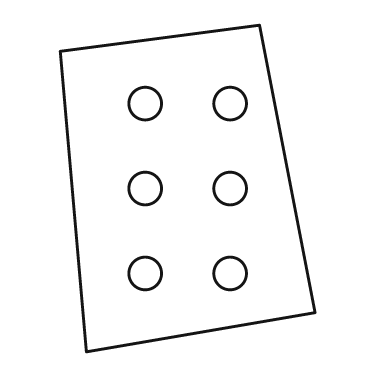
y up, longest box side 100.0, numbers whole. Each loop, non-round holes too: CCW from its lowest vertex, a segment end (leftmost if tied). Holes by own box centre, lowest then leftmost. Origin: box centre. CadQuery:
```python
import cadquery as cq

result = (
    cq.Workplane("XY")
    .moveTo(-31.0, -50.0)
    .lineTo(39.0, -38.0)
    .lineTo(22.0, 50.0)
    .lineTo(-39.0, 42.0)
    .close()
    .moveTo(-13.0, -26.0)
    .circle(5.0)
    .moveTo(13.0, -26.0)
    .circle(5.0)
    .moveTo(-13.0, 0.0)
    .circle(5.0)
    .moveTo(13.0, 0.0)
    .circle(5.0)
    .moveTo(-13.0, 26.0)
    .circle(5.0)
    .moveTo(13.0, 26.0)
    .circle(5.0)
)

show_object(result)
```